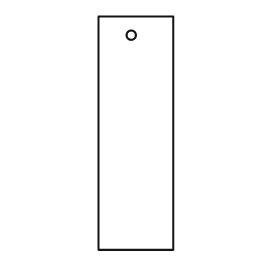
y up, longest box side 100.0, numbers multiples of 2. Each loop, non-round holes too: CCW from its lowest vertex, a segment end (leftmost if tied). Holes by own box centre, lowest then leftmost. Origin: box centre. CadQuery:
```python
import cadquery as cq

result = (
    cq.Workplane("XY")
    .moveTo(-16.0, -50.0)
    .lineTo(16.0, -50.0)
    .lineTo(16.0, 50.0)
    .lineTo(-16.0, 50.0)
    .close()
    .moveTo(-2.0, 42.0)
    .circle(2.0)
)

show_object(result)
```